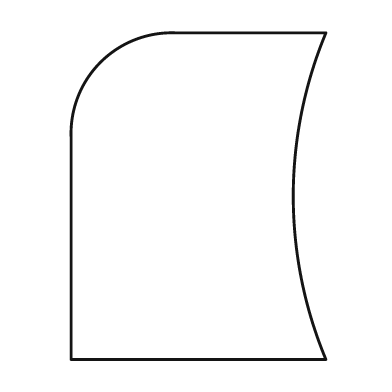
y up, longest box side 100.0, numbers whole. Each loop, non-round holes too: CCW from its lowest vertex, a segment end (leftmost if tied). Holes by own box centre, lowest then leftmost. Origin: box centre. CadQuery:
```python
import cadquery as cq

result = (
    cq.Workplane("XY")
    .moveTo(-39.0, -50.0)
    .lineTo(39.0, -50.0)
    .threePointArc((29.0, 0.0), (39.0, 50.0))
    .lineTo(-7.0, 50.0)
    .threePointArc((-30.0, 41.0), (-39.0, 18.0))
    .close()
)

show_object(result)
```